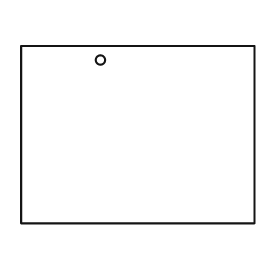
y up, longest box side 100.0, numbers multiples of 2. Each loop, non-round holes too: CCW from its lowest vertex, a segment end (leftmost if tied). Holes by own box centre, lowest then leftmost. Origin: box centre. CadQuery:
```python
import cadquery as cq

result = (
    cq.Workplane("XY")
    .moveTo(-50.0, -38.0)
    .lineTo(50.0, -38.0)
    .lineTo(50.0, 38.0)
    .lineTo(-50.0, 38.0)
    .close()
    .moveTo(-16.0, 32.0)
    .circle(2.0)
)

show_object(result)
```